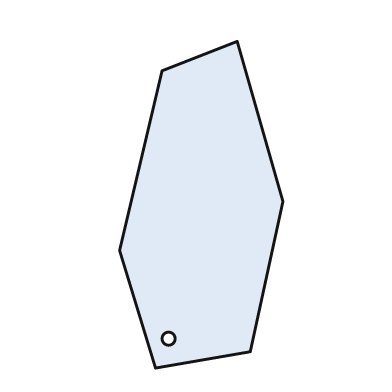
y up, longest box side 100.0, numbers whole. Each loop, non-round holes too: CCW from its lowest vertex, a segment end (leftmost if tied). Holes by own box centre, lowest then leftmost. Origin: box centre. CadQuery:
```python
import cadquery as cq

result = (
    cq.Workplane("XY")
    .moveTo(-14.0, -50.0)
    .lineTo(15.0, -45.0)
    .lineTo(25.0, 1.0)
    .lineTo(11.0, 50.0)
    .lineTo(-12.0, 41.0)
    .lineTo(-25.0, -14.0)
    .close()
    .moveTo(-10.0, -41.0)
    .circle(2.0)
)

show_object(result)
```